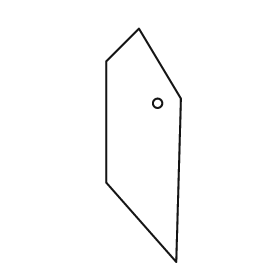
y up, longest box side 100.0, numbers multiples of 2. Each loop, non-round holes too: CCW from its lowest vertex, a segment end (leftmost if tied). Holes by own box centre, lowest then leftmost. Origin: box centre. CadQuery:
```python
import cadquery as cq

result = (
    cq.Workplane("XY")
    .moveTo(14.0, -50.0)
    .lineTo(16.0, 20.0)
    .lineTo(-2.0, 50.0)
    .lineTo(-16.0, 36.0)
    .lineTo(-16.0, -16.0)
    .close()
    .moveTo(6.0, 18.0)
    .circle(2.0)
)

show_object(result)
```